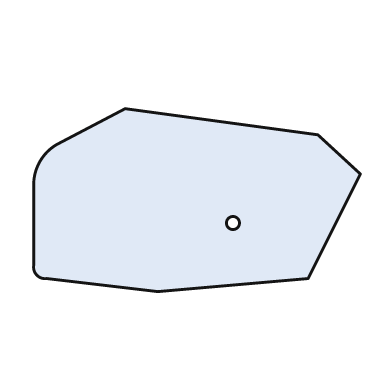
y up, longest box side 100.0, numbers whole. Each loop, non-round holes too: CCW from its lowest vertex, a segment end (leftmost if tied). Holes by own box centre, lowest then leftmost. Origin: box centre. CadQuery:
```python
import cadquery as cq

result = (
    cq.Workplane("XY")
    .moveTo(-12.0, -28.0)
    .lineTo(34.0, -24.0)
    .lineTo(50.0, 8.0)
    .lineTo(37.0, 20.0)
    .lineTo(-22.0, 28.0)
    .lineTo(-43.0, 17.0)
    .threePointArc((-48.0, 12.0), (-50.0, 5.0))
    .lineTo(-50.0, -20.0)
    .threePointArc((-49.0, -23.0), (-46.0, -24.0))
    .close()
    .moveTo(11.0, -7.0)
    .circle(2.0)
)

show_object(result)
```